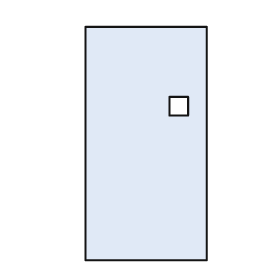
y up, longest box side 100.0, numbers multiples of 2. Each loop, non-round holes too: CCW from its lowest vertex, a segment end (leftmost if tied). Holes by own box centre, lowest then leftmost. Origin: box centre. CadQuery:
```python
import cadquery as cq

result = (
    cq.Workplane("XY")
    .moveTo(-26.0, -50.0)
    .lineTo(26.0, -50.0)
    .lineTo(26.0, 50.0)
    .lineTo(-26.0, 50.0)
    .close()
    .moveTo(10.0, 12.0)
    .lineTo(18.0, 12.0)
    .lineTo(18.0, 20.0)
    .lineTo(10.0, 20.0)
    .close()
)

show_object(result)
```